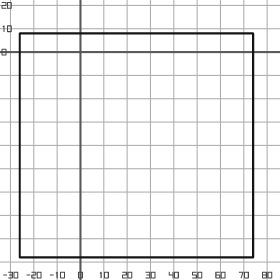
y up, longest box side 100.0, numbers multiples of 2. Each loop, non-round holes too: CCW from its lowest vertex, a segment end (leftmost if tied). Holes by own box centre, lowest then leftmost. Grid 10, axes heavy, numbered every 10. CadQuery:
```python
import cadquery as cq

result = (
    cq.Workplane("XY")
    .moveTo(-26.0, -88.0)
    .lineTo(74.0, -88.0)
    .lineTo(74.0, 8.0)
    .lineTo(-26.0, 8.0)
    .close()
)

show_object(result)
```